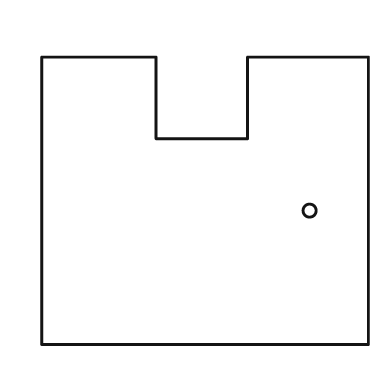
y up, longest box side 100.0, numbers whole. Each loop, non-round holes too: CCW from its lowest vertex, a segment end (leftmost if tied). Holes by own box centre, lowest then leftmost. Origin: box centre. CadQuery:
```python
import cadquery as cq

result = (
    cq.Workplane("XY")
    .moveTo(-50.0, -44.0)
    .lineTo(50.0, -44.0)
    .lineTo(50.0, 44.0)
    .lineTo(13.0, 44.0)
    .lineTo(13.0, 19.0)
    .lineTo(-15.0, 19.0)
    .lineTo(-15.0, 44.0)
    .lineTo(-50.0, 44.0)
    .close()
    .moveTo(32.0, -3.0)
    .circle(2.0)
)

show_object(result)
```